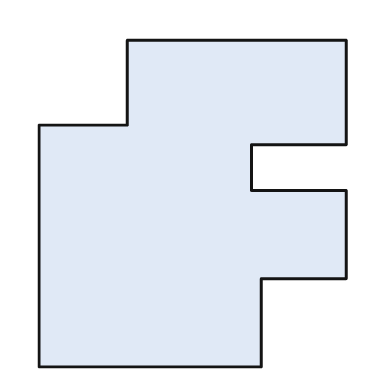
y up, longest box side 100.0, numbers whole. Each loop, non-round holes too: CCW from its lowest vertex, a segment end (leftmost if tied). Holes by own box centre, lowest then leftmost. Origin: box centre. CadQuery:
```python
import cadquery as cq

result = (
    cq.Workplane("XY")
    .moveTo(-47.0, -50.0)
    .lineTo(21.0, -50.0)
    .lineTo(21.0, -23.0)
    .lineTo(47.0, -23.0)
    .lineTo(47.0, 4.0)
    .lineTo(18.0, 4.0)
    .lineTo(18.0, 18.0)
    .lineTo(47.0, 18.0)
    .lineTo(47.0, 50.0)
    .lineTo(-20.0, 50.0)
    .lineTo(-20.0, 24.0)
    .lineTo(-47.0, 24.0)
    .close()
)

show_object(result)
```